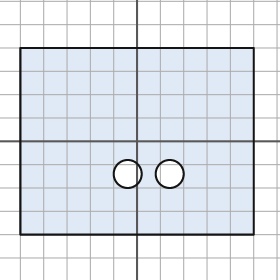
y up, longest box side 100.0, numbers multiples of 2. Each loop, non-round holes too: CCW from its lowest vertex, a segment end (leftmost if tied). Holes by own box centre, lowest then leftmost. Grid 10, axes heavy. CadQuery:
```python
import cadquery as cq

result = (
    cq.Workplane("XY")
    .moveTo(-50.0, -40.0)
    .lineTo(50.0, -40.0)
    .lineTo(50.0, 40.0)
    .lineTo(-50.0, 40.0)
    .close()
    .moveTo(-4.0, -14.0)
    .circle(6.0)
    .moveTo(14.0, -14.0)
    .circle(6.0)
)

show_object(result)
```